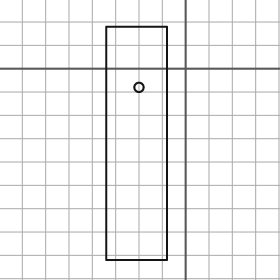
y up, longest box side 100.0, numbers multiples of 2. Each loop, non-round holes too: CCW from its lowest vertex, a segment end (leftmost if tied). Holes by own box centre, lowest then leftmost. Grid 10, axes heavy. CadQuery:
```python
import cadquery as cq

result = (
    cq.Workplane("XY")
    .moveTo(-34.0, -82.0)
    .lineTo(-8.0, -82.0)
    .lineTo(-8.0, 18.0)
    .lineTo(-34.0, 18.0)
    .close()
    .moveTo(-20.0, -8.0)
    .circle(2.0)
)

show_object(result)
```